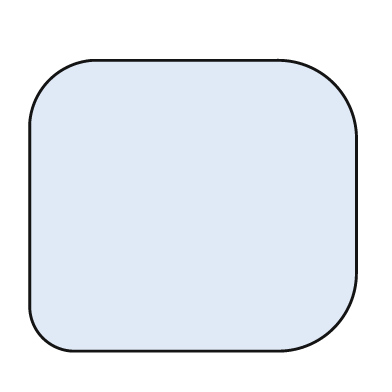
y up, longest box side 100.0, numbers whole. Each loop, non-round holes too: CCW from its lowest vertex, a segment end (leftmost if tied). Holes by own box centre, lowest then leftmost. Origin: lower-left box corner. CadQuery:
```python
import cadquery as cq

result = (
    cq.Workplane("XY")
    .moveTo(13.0, 0.0)
    .lineTo(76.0, 0.0)
    .threePointArc((93.0, 7.0), (100.0, 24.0))
    .lineTo(100.0, 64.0)
    .threePointArc((93.0, 82.0), (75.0, 89.0))
    .lineTo(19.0, 89.0)
    .threePointArc((6.0, 83.0), (0.0, 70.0))
    .lineTo(0.0, 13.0)
    .threePointArc((4.0, 4.0), (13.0, 0.0))
    .close()
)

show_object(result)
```